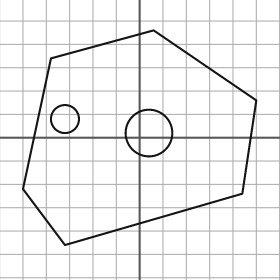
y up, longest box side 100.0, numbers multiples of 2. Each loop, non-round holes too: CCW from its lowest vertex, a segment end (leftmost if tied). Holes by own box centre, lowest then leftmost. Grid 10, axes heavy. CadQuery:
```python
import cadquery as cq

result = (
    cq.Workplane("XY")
    .moveTo(-32.0, -46.0)
    .lineTo(44.0, -24.0)
    .lineTo(50.0, 16.0)
    .lineTo(6.0, 46.0)
    .lineTo(-38.0, 34.0)
    .lineTo(-50.0, -22.0)
    .close()
    .moveTo(4.0, 2.0)
    .circle(10.0)
    .moveTo(-32.0, 8.0)
    .circle(6.0)
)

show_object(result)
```